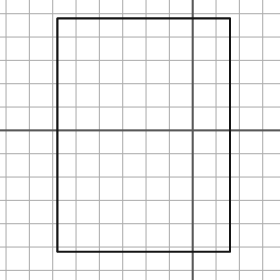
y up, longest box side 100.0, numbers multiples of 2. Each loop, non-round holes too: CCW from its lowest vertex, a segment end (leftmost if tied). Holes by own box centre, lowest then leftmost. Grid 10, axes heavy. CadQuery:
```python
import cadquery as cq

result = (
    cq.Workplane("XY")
    .moveTo(-58.0, -52.0)
    .lineTo(16.0, -52.0)
    .lineTo(16.0, 48.0)
    .lineTo(-58.0, 48.0)
    .close()
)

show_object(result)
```